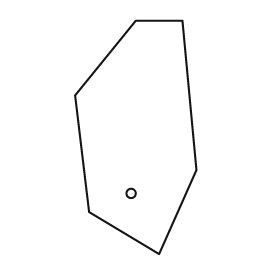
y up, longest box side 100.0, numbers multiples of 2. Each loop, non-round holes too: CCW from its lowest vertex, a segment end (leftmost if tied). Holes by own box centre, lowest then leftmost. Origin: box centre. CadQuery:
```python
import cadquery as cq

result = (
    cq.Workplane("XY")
    .moveTo(10.0, -50.0)
    .lineTo(26.0, -14.0)
    .lineTo(20.0, 50.0)
    .lineTo(0.0, 50.0)
    .lineTo(-26.0, 18.0)
    .lineTo(-20.0, -32.0)
    .close()
    .moveTo(-2.0, -24.0)
    .circle(2.0)
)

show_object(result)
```